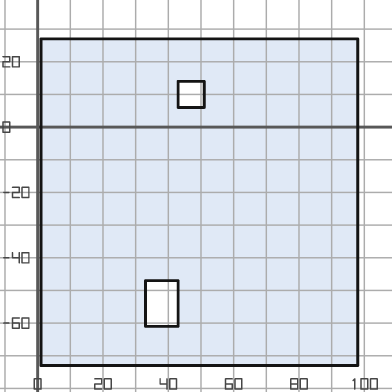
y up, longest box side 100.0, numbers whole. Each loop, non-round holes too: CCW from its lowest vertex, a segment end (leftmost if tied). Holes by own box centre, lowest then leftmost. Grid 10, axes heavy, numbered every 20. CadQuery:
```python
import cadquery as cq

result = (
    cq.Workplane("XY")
    .moveTo(1.0, -73.0)
    .lineTo(98.0, -73.0)
    .lineTo(98.0, 27.0)
    .lineTo(1.0, 27.0)
    .close()
    .moveTo(33.0, -61.0)
    .lineTo(43.0, -61.0)
    .lineTo(43.0, -47.0)
    .lineTo(33.0, -47.0)
    .close()
    .moveTo(43.0, 6.0)
    .lineTo(51.0, 6.0)
    .lineTo(51.0, 14.0)
    .lineTo(43.0, 14.0)
    .close()
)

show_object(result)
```